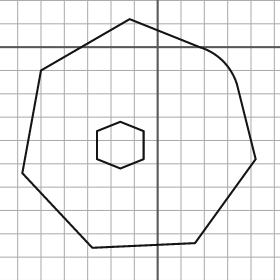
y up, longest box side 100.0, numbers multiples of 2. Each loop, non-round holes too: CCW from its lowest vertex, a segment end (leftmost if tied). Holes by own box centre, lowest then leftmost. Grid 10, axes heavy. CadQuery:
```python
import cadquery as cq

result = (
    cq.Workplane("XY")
    .moveTo(-28.0, -86.0)
    .lineTo(16.0, -84.0)
    .lineTo(42.0, -48.0)
    .lineTo(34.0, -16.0)
    .threePointArc((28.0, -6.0), (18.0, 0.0))
    .lineTo(-12.0, 12.0)
    .lineTo(-50.0, -10.0)
    .lineTo(-58.0, -54.0)
    .close()
    .moveTo(-16.0, -52.0)
    .lineTo(-6.0, -48.0)
    .lineTo(-6.0, -36.0)
    .lineTo(-16.0, -32.0)
    .lineTo(-26.0, -36.0)
    .lineTo(-26.0, -48.0)
    .close()
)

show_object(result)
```